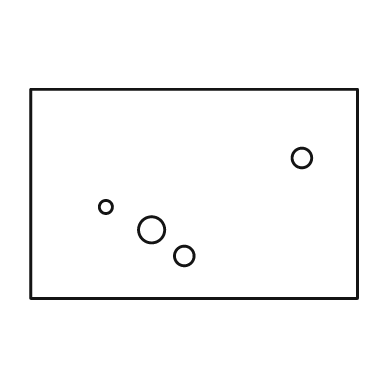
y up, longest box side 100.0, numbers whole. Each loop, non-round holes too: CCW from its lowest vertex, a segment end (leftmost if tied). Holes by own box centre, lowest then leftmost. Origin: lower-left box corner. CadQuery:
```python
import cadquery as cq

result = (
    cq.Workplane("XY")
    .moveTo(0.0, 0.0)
    .lineTo(100.0, 0.0)
    .lineTo(100.0, 64.0)
    .lineTo(0.0, 64.0)
    .close()
    .moveTo(47.0, 13.0)
    .circle(3.0)
    .moveTo(37.0, 21.0)
    .circle(4.0)
    .moveTo(23.0, 28.0)
    .circle(2.0)
    .moveTo(83.0, 43.0)
    .circle(3.0)
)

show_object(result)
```